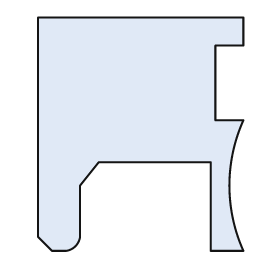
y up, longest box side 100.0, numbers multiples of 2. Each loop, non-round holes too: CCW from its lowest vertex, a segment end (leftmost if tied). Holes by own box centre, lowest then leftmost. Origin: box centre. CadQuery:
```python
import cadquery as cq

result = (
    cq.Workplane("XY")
    .moveTo(-38.0, -50.0)
    .lineTo(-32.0, -50.0)
    .threePointArc((-28.0, -48.0), (-26.0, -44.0))
    .lineTo(-26.0, -22.0)
    .lineTo(-18.0, -12.0)
    .lineTo(30.0, -12.0)
    .lineTo(30.0, -50.0)
    .lineTo(44.0, -50.0)
    .threePointArc((38.0, -22.0), (44.0, 6.0))
    .lineTo(32.0, 6.0)
    .lineTo(32.0, 38.0)
    .lineTo(44.0, 38.0)
    .lineTo(44.0, 50.0)
    .lineTo(-44.0, 50.0)
    .lineTo(-44.0, -44.0)
    .close()
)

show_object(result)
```